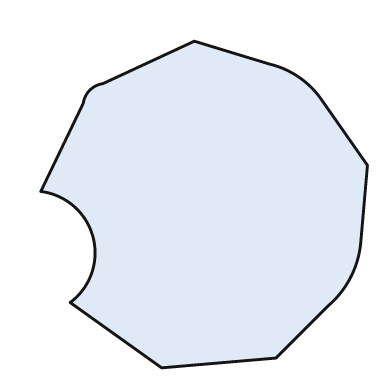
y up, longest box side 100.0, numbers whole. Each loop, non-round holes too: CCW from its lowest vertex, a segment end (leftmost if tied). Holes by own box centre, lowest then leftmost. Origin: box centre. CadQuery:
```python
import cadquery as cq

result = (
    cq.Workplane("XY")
    .moveTo(-13.0, -50.0)
    .lineTo(22.0, -47.0)
    .lineTo(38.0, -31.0)
    .threePointArc((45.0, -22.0), (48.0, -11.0))
    .lineTo(50.0, 12.0)
    .lineTo(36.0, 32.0)
    .threePointArc((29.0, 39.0), (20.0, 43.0))
    .lineTo(-3.0, 50.0)
    .lineTo(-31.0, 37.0)
    .threePointArc((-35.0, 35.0), (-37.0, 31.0))
    .lineTo(-50.0, 4.0)
    .threePointArc((-34.0, -10.0), (-41.0, -30.0))
    .close()
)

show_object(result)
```